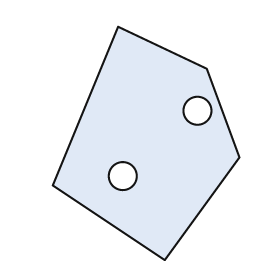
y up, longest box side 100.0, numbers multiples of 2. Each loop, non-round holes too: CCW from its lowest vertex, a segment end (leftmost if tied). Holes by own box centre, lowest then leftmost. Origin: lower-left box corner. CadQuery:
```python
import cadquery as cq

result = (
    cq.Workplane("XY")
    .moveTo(48.0, 0.0)
    .lineTo(80.0, 44.0)
    .lineTo(66.0, 82.0)
    .lineTo(28.0, 100.0)
    .lineTo(0.0, 32.0)
    .close()
    .moveTo(30.0, 36.0)
    .circle(6.0)
    .moveTo(62.0, 64.0)
    .circle(6.0)
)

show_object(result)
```